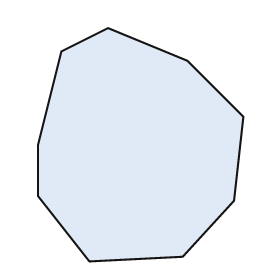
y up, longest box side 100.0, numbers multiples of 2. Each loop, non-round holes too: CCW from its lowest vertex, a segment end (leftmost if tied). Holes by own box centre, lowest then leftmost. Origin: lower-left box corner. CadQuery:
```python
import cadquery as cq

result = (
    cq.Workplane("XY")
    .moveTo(22.0, 0.0)
    .lineTo(62.0, 2.0)
    .lineTo(84.0, 26.0)
    .lineTo(88.0, 62.0)
    .lineTo(64.0, 86.0)
    .lineTo(30.0, 100.0)
    .lineTo(10.0, 90.0)
    .lineTo(0.0, 50.0)
    .lineTo(0.0, 28.0)
    .close()
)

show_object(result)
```